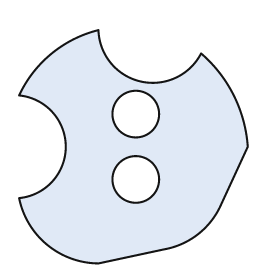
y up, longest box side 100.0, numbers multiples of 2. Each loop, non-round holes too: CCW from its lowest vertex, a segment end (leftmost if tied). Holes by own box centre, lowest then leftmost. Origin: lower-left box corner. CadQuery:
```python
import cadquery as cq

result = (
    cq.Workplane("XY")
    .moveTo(34.0, 0.0)
    .lineTo(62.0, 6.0)
    .threePointArc((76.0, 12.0), (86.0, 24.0))
    .lineTo(98.0, 50.0)
    .threePointArc((92.0, 72.0), (78.0, 90.0))
    .threePointArc((52.0, 78.0), (34.0, 100.0))
    .threePointArc((14.0, 90.0), (0.0, 72.0))
    .threePointArc((20.0, 50.0), (0.0, 28.0))
    .threePointArc((12.0, 8.0), (34.0, 0.0))
    .close()
    .moveTo(50.0, 36.0)
    .circle(10.0)
    .moveTo(50.0, 64.0)
    .circle(10.0)
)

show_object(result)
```